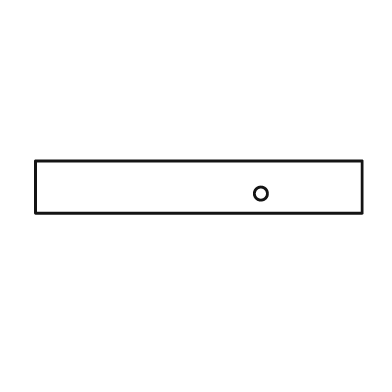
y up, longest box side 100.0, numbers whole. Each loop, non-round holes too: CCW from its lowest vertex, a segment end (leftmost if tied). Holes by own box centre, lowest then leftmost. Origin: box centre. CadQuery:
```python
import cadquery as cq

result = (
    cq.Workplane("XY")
    .moveTo(-50.0, -8.0)
    .lineTo(50.0, -8.0)
    .lineTo(50.0, 8.0)
    .lineTo(-50.0, 8.0)
    .close()
    .moveTo(19.0, -2.0)
    .circle(2.0)
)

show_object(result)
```